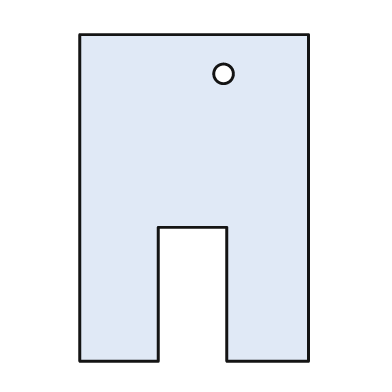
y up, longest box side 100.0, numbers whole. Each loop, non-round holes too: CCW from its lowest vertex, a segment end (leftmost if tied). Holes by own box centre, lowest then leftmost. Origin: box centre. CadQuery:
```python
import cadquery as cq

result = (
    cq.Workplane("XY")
    .moveTo(-35.0, -50.0)
    .lineTo(-11.0, -50.0)
    .lineTo(-11.0, -9.0)
    .lineTo(10.0, -9.0)
    .lineTo(10.0, -50.0)
    .lineTo(35.0, -50.0)
    .lineTo(35.0, 50.0)
    .lineTo(-35.0, 50.0)
    .close()
    .moveTo(9.0, 38.0)
    .circle(3.0)
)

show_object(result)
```